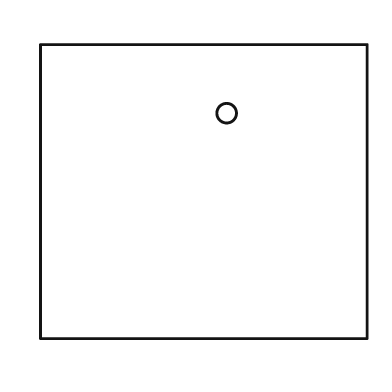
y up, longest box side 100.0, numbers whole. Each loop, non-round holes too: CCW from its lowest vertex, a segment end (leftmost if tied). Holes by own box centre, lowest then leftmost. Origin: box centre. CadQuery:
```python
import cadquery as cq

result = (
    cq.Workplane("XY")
    .moveTo(-50.0, -45.0)
    .lineTo(50.0, -45.0)
    .lineTo(50.0, 45.0)
    .lineTo(-50.0, 45.0)
    .close()
    .moveTo(7.0, 24.0)
    .circle(3.0)
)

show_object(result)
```